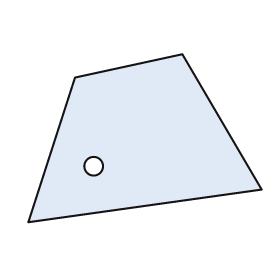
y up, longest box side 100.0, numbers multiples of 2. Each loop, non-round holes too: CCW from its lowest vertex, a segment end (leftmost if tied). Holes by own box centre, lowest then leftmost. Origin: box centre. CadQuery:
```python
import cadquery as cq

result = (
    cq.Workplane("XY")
    .moveTo(-50.0, -36.0)
    .lineTo(50.0, -22.0)
    .lineTo(16.0, 36.0)
    .lineTo(-30.0, 26.0)
    .close()
    .moveTo(-22.0, -12.0)
    .circle(4.0)
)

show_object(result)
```